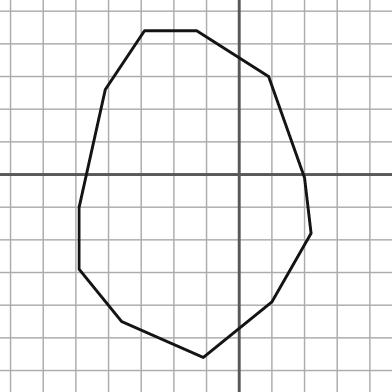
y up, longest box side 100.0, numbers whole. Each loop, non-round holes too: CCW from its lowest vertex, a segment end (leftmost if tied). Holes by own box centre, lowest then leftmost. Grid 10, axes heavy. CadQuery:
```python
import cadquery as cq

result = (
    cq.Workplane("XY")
    .moveTo(-11.0, -56.0)
    .lineTo(10.0, -39.0)
    .lineTo(22.0, -18.0)
    .lineTo(20.0, -1.0)
    .lineTo(9.0, 30.0)
    .lineTo(-13.0, 44.0)
    .lineTo(-29.0, 44.0)
    .lineTo(-41.0, 26.0)
    .lineTo(-49.0, -10.0)
    .lineTo(-49.0, -29.0)
    .lineTo(-36.0, -45.0)
    .close()
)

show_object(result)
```